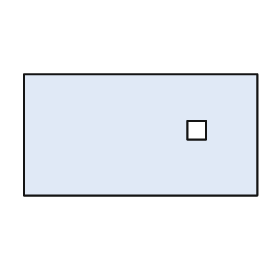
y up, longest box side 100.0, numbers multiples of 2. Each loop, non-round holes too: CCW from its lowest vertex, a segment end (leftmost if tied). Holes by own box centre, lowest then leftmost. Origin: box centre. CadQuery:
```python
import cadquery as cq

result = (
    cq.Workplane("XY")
    .moveTo(-50.0, -26.0)
    .lineTo(50.0, -26.0)
    .lineTo(50.0, 26.0)
    .lineTo(-50.0, 26.0)
    .close()
    .moveTo(20.0, -2.0)
    .lineTo(28.0, -2.0)
    .lineTo(28.0, 6.0)
    .lineTo(20.0, 6.0)
    .close()
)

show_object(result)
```